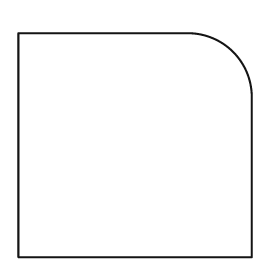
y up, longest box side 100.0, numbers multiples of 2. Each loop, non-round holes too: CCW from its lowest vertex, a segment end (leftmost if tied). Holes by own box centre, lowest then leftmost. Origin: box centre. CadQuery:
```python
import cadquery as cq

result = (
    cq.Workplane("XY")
    .moveTo(-50.0, -48.0)
    .lineTo(50.0, -48.0)
    .lineTo(50.0, 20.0)
    .threePointArc((42.0, 40.0), (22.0, 48.0))
    .lineTo(-50.0, 48.0)
    .close()
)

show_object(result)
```